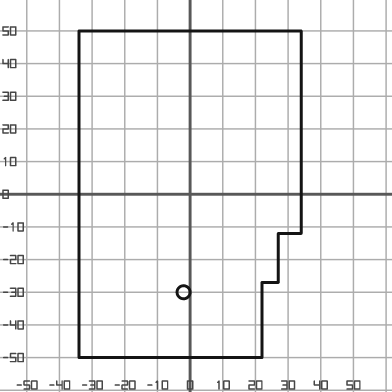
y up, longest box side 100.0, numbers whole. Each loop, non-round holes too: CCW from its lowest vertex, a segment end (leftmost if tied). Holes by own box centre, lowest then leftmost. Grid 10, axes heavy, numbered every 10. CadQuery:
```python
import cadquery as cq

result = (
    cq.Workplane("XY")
    .moveTo(-34.0, -50.0)
    .lineTo(22.0, -50.0)
    .lineTo(22.0, -27.0)
    .lineTo(27.0, -27.0)
    .lineTo(27.0, -12.0)
    .lineTo(34.0, -12.0)
    .lineTo(34.0, 50.0)
    .lineTo(-34.0, 50.0)
    .close()
    .moveTo(-2.0, -30.0)
    .circle(2.0)
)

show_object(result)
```